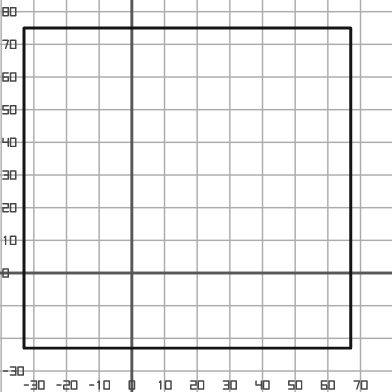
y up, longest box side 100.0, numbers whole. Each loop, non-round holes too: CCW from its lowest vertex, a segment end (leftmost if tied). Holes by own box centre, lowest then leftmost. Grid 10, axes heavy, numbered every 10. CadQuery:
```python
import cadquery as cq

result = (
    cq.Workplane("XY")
    .moveTo(-33.0, -23.0)
    .lineTo(67.0, -23.0)
    .lineTo(67.0, 75.0)
    .lineTo(-33.0, 75.0)
    .close()
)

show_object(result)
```